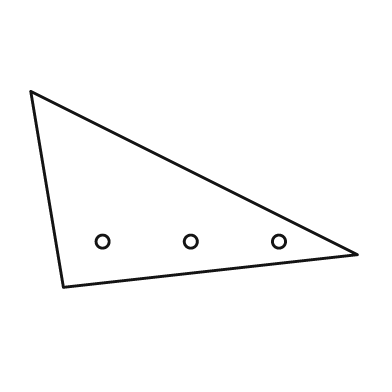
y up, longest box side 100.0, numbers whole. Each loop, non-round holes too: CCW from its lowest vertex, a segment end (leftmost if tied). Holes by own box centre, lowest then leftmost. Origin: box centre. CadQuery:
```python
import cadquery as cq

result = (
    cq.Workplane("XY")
    .moveTo(-40.0, -30.0)
    .lineTo(50.0, -20.0)
    .lineTo(-50.0, 30.0)
    .close()
    .moveTo(-28.0, -16.0)
    .circle(2.0)
    .moveTo(-1.0, -16.0)
    .circle(2.0)
    .moveTo(26.0, -16.0)
    .circle(2.0)
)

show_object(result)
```